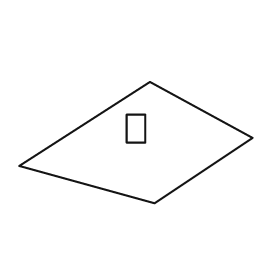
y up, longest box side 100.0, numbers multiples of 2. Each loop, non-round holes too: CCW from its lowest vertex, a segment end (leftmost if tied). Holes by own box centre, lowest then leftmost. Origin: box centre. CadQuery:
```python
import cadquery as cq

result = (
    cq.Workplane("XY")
    .moveTo(8.0, -26.0)
    .lineTo(50.0, 2.0)
    .lineTo(6.0, 26.0)
    .lineTo(-50.0, -10.0)
    .close()
    .moveTo(-4.0, 0.0)
    .lineTo(4.0, 0.0)
    .lineTo(4.0, 12.0)
    .lineTo(-4.0, 12.0)
    .close()
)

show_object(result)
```